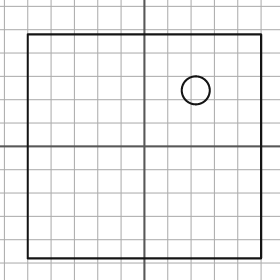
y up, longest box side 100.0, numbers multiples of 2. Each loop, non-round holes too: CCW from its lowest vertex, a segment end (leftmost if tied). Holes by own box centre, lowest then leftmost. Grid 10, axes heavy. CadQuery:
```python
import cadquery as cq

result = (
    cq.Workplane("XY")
    .moveTo(-50.0, -48.0)
    .lineTo(50.0, -48.0)
    .lineTo(50.0, 48.0)
    .lineTo(-50.0, 48.0)
    .close()
    .moveTo(22.0, 24.0)
    .circle(6.0)
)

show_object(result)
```